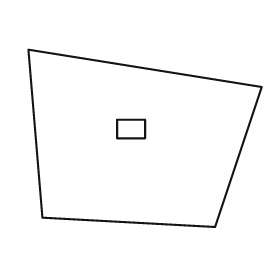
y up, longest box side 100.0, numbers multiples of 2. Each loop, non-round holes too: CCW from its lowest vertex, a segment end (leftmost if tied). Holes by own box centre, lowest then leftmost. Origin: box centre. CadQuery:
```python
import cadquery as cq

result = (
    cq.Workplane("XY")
    .moveTo(30.0, -38.0)
    .lineTo(50.0, 22.0)
    .lineTo(-50.0, 38.0)
    .lineTo(-44.0, -34.0)
    .close()
    .moveTo(-12.0, 0.0)
    .lineTo(0.0, 0.0)
    .lineTo(0.0, 8.0)
    .lineTo(-12.0, 8.0)
    .close()
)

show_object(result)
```